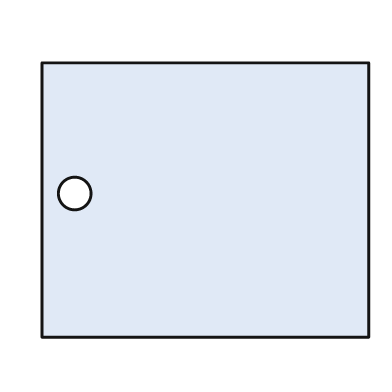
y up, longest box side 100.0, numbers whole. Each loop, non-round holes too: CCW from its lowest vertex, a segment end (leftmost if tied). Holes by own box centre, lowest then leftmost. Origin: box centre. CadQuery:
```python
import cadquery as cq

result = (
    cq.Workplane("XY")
    .moveTo(-50.0, -42.0)
    .lineTo(50.0, -42.0)
    .lineTo(50.0, 42.0)
    .lineTo(-50.0, 42.0)
    .close()
    .moveTo(-40.0, 2.0)
    .circle(5.0)
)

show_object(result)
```